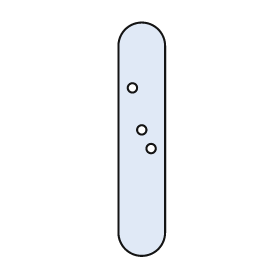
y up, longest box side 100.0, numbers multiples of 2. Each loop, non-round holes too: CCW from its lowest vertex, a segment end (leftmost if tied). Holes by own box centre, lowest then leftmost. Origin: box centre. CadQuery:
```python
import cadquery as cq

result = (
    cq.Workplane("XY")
    .moveTo(-10.0, -40.0)
    .threePointArc((0.0, -50.0), (10.0, -40.0))
    .lineTo(10.0, 40.0)
    .threePointArc((0.0, 50.0), (-10.0, 40.0))
    .close()
    .moveTo(4.0, -4.0)
    .circle(2.0)
    .moveTo(0.0, 4.0)
    .circle(2.0)
    .moveTo(-4.0, 22.0)
    .circle(2.0)
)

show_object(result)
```